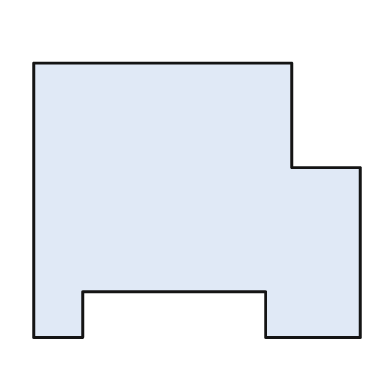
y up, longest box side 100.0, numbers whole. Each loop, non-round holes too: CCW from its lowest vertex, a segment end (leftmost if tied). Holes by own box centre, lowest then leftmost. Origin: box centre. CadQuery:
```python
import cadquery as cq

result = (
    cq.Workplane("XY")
    .moveTo(-50.0, -42.0)
    .lineTo(-35.0, -42.0)
    .lineTo(-35.0, -28.0)
    .lineTo(21.0, -28.0)
    .lineTo(21.0, -42.0)
    .lineTo(50.0, -42.0)
    .lineTo(50.0, 10.0)
    .lineTo(29.0, 10.0)
    .lineTo(29.0, 42.0)
    .lineTo(-50.0, 42.0)
    .close()
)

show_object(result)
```